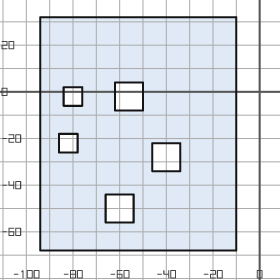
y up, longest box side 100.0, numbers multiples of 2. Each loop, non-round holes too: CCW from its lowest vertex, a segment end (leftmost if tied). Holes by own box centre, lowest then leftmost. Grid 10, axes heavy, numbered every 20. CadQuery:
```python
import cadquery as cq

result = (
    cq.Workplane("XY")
    .moveTo(-94.0, -68.0)
    .lineTo(-10.0, -68.0)
    .lineTo(-10.0, 32.0)
    .lineTo(-94.0, 32.0)
    .close()
    .moveTo(-66.0, -56.0)
    .lineTo(-54.0, -56.0)
    .lineTo(-54.0, -44.0)
    .lineTo(-66.0, -44.0)
    .close()
    .moveTo(-46.0, -34.0)
    .lineTo(-34.0, -34.0)
    .lineTo(-34.0, -22.0)
    .lineTo(-46.0, -22.0)
    .close()
    .moveTo(-86.0, -26.0)
    .lineTo(-78.0, -26.0)
    .lineTo(-78.0, -18.0)
    .lineTo(-86.0, -18.0)
    .close()
    .moveTo(-84.0, -6.0)
    .lineTo(-76.0, -6.0)
    .lineTo(-76.0, 2.0)
    .lineTo(-84.0, 2.0)
    .close()
    .moveTo(-62.0, -8.0)
    .lineTo(-50.0, -8.0)
    .lineTo(-50.0, 4.0)
    .lineTo(-62.0, 4.0)
    .close()
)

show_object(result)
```